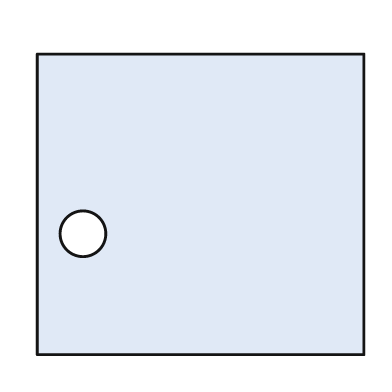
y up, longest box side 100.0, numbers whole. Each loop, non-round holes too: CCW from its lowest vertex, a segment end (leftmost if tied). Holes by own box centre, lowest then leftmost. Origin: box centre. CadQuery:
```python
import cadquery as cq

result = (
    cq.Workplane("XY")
    .moveTo(-50.0, -46.0)
    .lineTo(50.0, -46.0)
    .lineTo(50.0, 46.0)
    .lineTo(-50.0, 46.0)
    .close()
    .moveTo(-36.0, -9.0)
    .circle(7.0)
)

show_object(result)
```